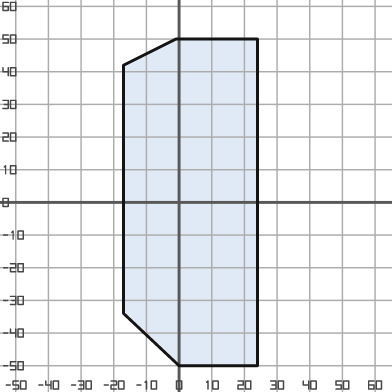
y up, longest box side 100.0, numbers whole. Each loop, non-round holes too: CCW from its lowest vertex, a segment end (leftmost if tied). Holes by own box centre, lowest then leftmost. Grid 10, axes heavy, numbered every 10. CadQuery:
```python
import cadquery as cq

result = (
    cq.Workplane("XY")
    .moveTo(0.0, -50.0)
    .lineTo(24.0, -50.0)
    .lineTo(24.0, 50.0)
    .lineTo(-1.0, 50.0)
    .lineTo(-17.0, 42.0)
    .lineTo(-17.0, -34.0)
    .close()
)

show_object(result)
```